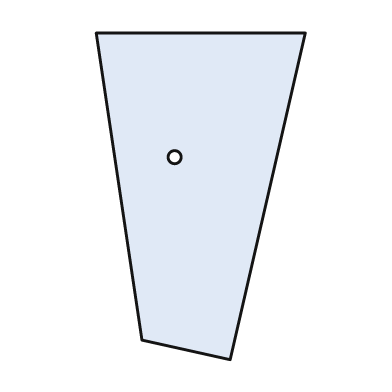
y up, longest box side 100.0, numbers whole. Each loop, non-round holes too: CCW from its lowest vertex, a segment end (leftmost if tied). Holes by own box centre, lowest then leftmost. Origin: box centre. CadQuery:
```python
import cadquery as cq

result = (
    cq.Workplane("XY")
    .moveTo(9.0, -50.0)
    .lineTo(32.0, 50.0)
    .lineTo(-32.0, 50.0)
    .lineTo(-18.0, -44.0)
    .close()
    .moveTo(-8.0, 12.0)
    .circle(2.0)
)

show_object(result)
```